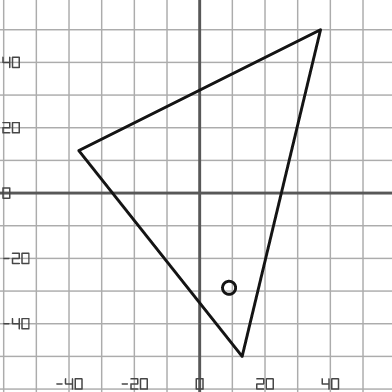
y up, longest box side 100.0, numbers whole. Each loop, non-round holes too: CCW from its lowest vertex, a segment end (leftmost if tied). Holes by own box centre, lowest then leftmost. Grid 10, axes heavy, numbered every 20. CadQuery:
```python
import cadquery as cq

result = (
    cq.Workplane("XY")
    .moveTo(13.0, -50.0)
    .lineTo(37.0, 50.0)
    .lineTo(-37.0, 13.0)
    .close()
    .moveTo(9.0, -29.0)
    .circle(2.0)
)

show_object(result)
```